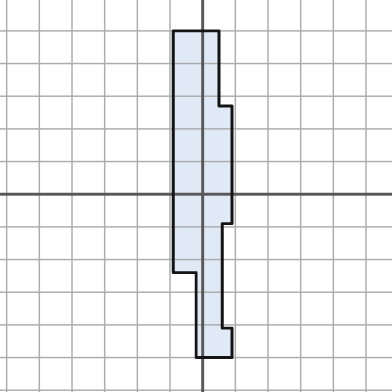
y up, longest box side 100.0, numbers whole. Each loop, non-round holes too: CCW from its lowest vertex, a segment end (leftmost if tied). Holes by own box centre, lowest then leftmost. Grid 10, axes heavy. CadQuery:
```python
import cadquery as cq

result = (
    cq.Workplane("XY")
    .moveTo(-2.0, -50.0)
    .lineTo(9.0, -50.0)
    .lineTo(9.0, -41.0)
    .lineTo(6.0, -41.0)
    .lineTo(6.0, -9.0)
    .lineTo(9.0, -9.0)
    .lineTo(9.0, 27.0)
    .lineTo(5.0, 27.0)
    .lineTo(5.0, 50.0)
    .lineTo(-9.0, 50.0)
    .lineTo(-9.0, -24.0)
    .lineTo(-2.0, -24.0)
    .close()
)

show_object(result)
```